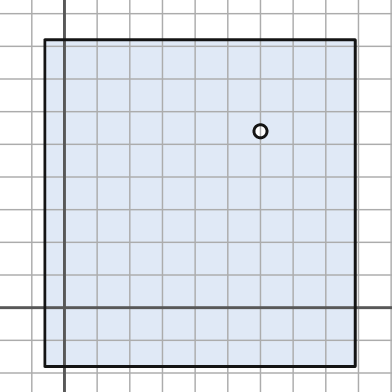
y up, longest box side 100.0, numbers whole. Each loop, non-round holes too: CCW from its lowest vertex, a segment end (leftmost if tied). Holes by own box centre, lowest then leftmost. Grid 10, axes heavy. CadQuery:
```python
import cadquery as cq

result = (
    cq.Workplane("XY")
    .moveTo(-6.0, -18.0)
    .lineTo(89.0, -18.0)
    .lineTo(89.0, 82.0)
    .lineTo(-6.0, 82.0)
    .close()
    .moveTo(60.0, 54.0)
    .circle(2.0)
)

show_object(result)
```